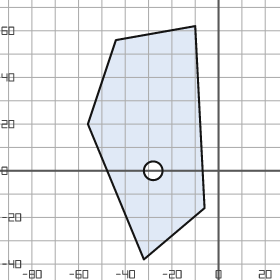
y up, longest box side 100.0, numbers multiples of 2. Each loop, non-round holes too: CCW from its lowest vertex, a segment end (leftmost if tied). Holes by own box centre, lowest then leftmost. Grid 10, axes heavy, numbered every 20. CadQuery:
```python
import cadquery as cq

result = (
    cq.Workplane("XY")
    .moveTo(-32.0, -38.0)
    .lineTo(-6.0, -16.0)
    .lineTo(-10.0, 62.0)
    .lineTo(-44.0, 56.0)
    .lineTo(-56.0, 20.0)
    .close()
    .moveTo(-28.0, 0.0)
    .circle(4.0)
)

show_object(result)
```